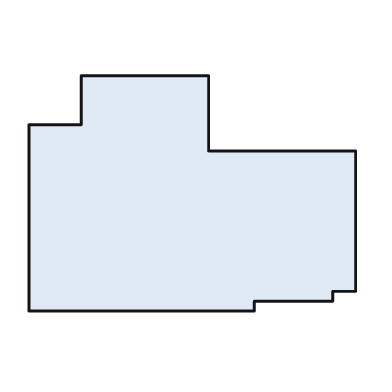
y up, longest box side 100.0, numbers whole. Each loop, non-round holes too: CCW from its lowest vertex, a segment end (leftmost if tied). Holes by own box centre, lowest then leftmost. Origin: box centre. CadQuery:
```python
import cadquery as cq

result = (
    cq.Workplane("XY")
    .moveTo(-50.0, -36.0)
    .lineTo(19.0, -36.0)
    .lineTo(19.0, -33.0)
    .lineTo(43.0, -33.0)
    .lineTo(43.0, -30.0)
    .lineTo(50.0, -30.0)
    .lineTo(50.0, 13.0)
    .lineTo(5.0, 13.0)
    .lineTo(5.0, 36.0)
    .lineTo(-34.0, 36.0)
    .lineTo(-34.0, 21.0)
    .lineTo(-50.0, 21.0)
    .close()
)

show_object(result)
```